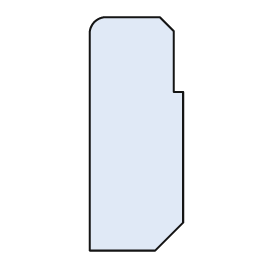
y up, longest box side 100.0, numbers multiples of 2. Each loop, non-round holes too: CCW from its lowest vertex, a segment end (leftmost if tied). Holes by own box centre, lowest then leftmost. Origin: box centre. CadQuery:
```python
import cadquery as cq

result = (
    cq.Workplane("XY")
    .moveTo(-20.0, -50.0)
    .lineTo(8.0, -50.0)
    .lineTo(20.0, -38.0)
    .lineTo(20.0, 18.0)
    .lineTo(16.0, 18.0)
    .lineTo(16.0, 44.0)
    .lineTo(10.0, 50.0)
    .lineTo(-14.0, 50.0)
    .threePointArc((-18.0, 48.0), (-20.0, 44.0))
    .close()
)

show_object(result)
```